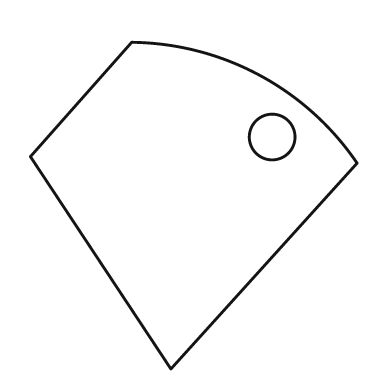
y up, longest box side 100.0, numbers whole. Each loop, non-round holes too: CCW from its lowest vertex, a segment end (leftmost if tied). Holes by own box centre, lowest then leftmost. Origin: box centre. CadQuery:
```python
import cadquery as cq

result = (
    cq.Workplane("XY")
    .moveTo(-7.0, -50.0)
    .lineTo(50.0, 13.0)
    .threePointArc((20.0, 40.0), (-19.0, 50.0))
    .lineTo(-50.0, 15.0)
    .close()
    .moveTo(24.0, 21.0)
    .circle(7.0)
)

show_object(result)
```